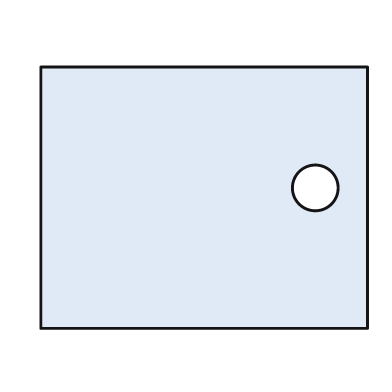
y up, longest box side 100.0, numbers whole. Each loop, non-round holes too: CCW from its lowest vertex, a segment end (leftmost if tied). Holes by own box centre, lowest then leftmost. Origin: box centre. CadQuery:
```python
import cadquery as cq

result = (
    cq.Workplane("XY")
    .moveTo(-50.0, -40.0)
    .lineTo(50.0, -40.0)
    .lineTo(50.0, 40.0)
    .lineTo(-50.0, 40.0)
    .close()
    .moveTo(34.0, 3.0)
    .circle(7.0)
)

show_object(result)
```